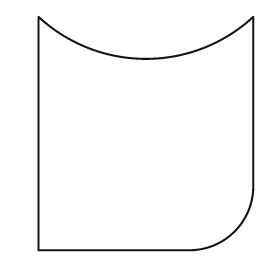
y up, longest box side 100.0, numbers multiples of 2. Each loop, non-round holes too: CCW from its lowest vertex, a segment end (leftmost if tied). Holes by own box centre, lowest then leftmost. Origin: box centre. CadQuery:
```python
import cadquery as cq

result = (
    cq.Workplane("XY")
    .moveTo(-46.0, -50.0)
    .lineTo(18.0, -50.0)
    .threePointArc((38.0, -42.0), (46.0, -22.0))
    .lineTo(46.0, 50.0)
    .threePointArc((0.0, 32.0), (-46.0, 50.0))
    .close()
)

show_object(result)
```